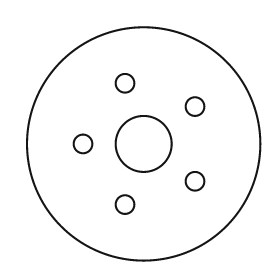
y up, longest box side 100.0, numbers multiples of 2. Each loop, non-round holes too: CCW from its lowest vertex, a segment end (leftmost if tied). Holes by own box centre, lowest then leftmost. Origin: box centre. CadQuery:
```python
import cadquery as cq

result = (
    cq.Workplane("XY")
    .moveTo(0.0, 0.0)
    .circle(50.0)
    .moveTo(-8.0, -26.0)
    .circle(4.0)
    .moveTo(22.0, -16.0)
    .circle(4.0)
    .moveTo(-26.0, 0.0)
    .circle(4.0)
    .moveTo(0.0, 0.0)
    .circle(12.0)
    .moveTo(22.0, 16.0)
    .circle(4.0)
    .moveTo(-8.0, 26.0)
    .circle(4.0)
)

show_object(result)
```